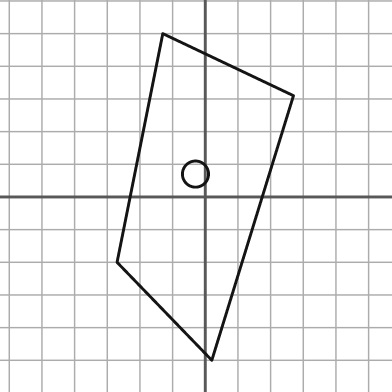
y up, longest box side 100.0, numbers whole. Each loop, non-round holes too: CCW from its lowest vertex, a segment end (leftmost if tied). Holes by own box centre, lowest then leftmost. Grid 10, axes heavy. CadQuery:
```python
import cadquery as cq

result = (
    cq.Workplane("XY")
    .moveTo(2.0, -50.0)
    .lineTo(27.0, 31.0)
    .lineTo(-13.0, 50.0)
    .lineTo(-27.0, -20.0)
    .close()
    .moveTo(-3.0, 7.0)
    .circle(4.0)
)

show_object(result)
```